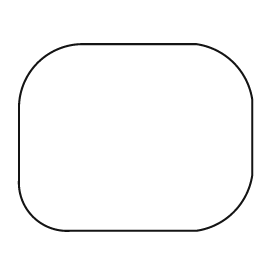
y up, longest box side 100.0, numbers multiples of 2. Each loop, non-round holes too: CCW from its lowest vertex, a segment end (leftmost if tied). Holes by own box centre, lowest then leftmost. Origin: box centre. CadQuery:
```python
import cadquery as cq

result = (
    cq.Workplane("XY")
    .moveTo(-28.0, -40.0)
    .lineTo(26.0, -40.0)
    .threePointArc((42.0, -32.0), (50.0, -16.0))
    .lineTo(50.0, 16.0)
    .threePointArc((42.0, 32.0), (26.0, 40.0))
    .lineTo(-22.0, 40.0)
    .threePointArc((-42.0, 32.0), (-50.0, 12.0))
    .lineTo(-50.0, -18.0)
    .threePointArc((-44.0, -34.0), (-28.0, -40.0))
    .close()
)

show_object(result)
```